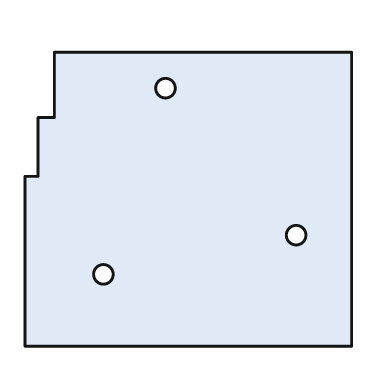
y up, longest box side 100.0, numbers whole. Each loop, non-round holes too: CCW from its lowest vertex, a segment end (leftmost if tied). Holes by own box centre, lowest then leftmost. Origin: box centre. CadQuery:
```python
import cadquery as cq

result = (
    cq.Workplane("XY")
    .moveTo(-50.0, -45.0)
    .lineTo(50.0, -45.0)
    .lineTo(50.0, 45.0)
    .lineTo(-41.0, 45.0)
    .lineTo(-41.0, 25.0)
    .lineTo(-46.0, 25.0)
    .lineTo(-46.0, 7.0)
    .lineTo(-50.0, 7.0)
    .close()
    .moveTo(-26.0, -23.0)
    .circle(3.0)
    .moveTo(33.0, -11.0)
    .circle(3.0)
    .moveTo(-7.0, 34.0)
    .circle(3.0)
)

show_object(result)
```